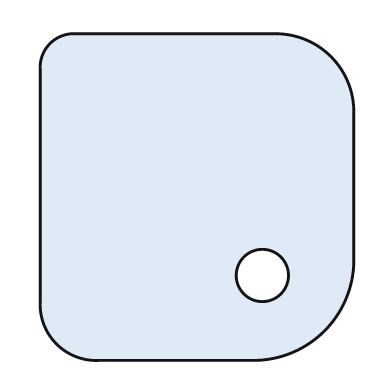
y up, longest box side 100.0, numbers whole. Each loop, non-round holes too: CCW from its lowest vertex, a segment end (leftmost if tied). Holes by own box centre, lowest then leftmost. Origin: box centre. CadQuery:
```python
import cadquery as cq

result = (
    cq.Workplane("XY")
    .moveTo(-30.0, -50.0)
    .lineTo(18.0, -50.0)
    .threePointArc((39.0, -41.0), (48.0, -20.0))
    .lineTo(48.0, 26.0)
    .threePointArc((41.0, 43.0), (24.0, 50.0))
    .lineTo(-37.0, 50.0)
    .threePointArc((-45.0, 47.0), (-48.0, 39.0))
    .lineTo(-48.0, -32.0)
    .threePointArc((-43.0, -45.0), (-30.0, -50.0))
    .close()
    .moveTo(20.0, -24.0)
    .circle(8.0)
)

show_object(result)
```